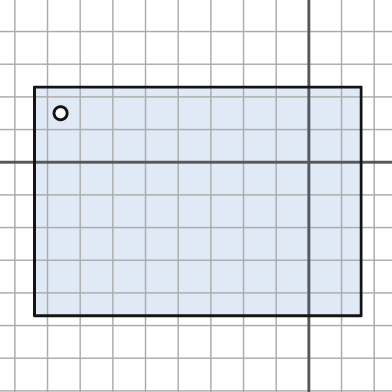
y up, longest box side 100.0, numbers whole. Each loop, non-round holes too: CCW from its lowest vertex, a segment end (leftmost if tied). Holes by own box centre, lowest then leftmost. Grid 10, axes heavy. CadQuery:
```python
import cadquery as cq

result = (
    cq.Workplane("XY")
    .moveTo(-84.0, -47.0)
    .lineTo(16.0, -47.0)
    .lineTo(16.0, 23.0)
    .lineTo(-84.0, 23.0)
    .close()
    .moveTo(-76.0, 15.0)
    .circle(2.0)
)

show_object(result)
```